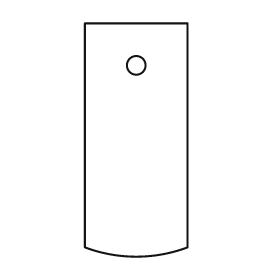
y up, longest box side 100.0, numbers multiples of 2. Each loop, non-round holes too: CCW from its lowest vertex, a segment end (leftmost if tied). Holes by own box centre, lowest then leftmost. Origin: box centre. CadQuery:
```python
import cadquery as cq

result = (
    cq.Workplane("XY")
    .moveTo(-22.0, -46.0)
    .threePointArc((0.0, -50.0), (22.0, -46.0))
    .lineTo(22.0, 50.0)
    .lineTo(-22.0, 50.0)
    .close()
    .moveTo(0.0, 32.0)
    .circle(4.0)
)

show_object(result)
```